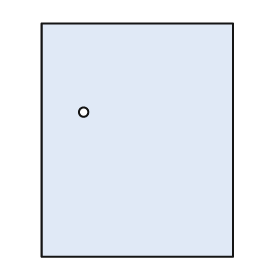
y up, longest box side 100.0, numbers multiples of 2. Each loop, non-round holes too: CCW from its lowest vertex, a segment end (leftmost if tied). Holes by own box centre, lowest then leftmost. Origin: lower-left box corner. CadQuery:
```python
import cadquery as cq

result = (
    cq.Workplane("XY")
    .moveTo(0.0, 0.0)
    .lineTo(82.0, 0.0)
    .lineTo(82.0, 100.0)
    .lineTo(0.0, 100.0)
    .close()
    .moveTo(18.0, 62.0)
    .circle(2.0)
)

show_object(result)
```